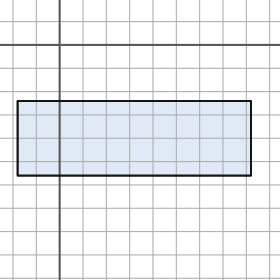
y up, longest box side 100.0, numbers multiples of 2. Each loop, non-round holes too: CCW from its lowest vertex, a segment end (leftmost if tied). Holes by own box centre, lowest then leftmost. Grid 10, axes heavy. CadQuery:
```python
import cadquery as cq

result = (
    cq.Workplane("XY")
    .moveTo(-18.0, -56.0)
    .lineTo(82.0, -56.0)
    .lineTo(82.0, -24.0)
    .lineTo(-18.0, -24.0)
    .close()
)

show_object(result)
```